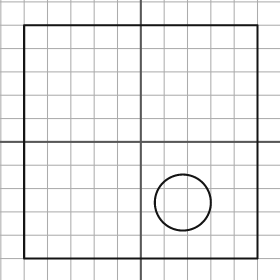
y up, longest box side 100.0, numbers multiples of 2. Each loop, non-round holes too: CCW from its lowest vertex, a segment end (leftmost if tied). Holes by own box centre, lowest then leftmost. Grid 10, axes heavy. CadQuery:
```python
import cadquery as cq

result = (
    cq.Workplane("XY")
    .moveTo(-50.0, -50.0)
    .lineTo(50.0, -50.0)
    .lineTo(50.0, 50.0)
    .lineTo(-50.0, 50.0)
    .close()
    .moveTo(18.0, -26.0)
    .circle(12.0)
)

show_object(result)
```